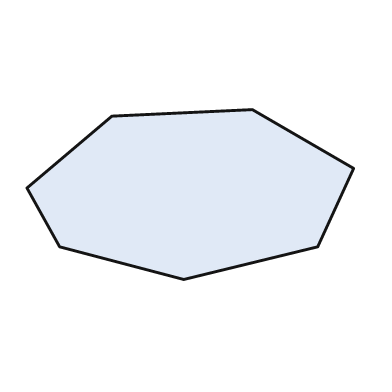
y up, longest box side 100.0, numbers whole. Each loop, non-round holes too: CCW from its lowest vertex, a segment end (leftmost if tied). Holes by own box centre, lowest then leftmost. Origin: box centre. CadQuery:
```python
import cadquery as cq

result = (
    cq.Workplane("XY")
    .moveTo(-2.0, -26.0)
    .lineTo(39.0, -16.0)
    .lineTo(50.0, 8.0)
    .lineTo(19.0, 26.0)
    .lineTo(-24.0, 24.0)
    .lineTo(-50.0, 2.0)
    .lineTo(-40.0, -16.0)
    .close()
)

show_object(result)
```